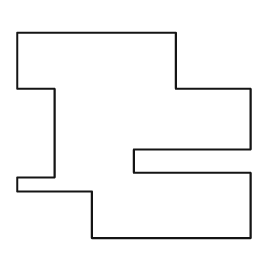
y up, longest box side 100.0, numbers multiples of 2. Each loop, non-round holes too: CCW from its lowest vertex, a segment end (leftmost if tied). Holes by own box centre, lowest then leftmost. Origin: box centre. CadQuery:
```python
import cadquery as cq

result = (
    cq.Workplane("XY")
    .moveTo(-18.0, -44.0)
    .lineTo(50.0, -44.0)
    .lineTo(50.0, -16.0)
    .lineTo(0.0, -16.0)
    .lineTo(0.0, -6.0)
    .lineTo(50.0, -6.0)
    .lineTo(50.0, 20.0)
    .lineTo(18.0, 20.0)
    .lineTo(18.0, 44.0)
    .lineTo(-50.0, 44.0)
    .lineTo(-50.0, 20.0)
    .lineTo(-34.0, 20.0)
    .lineTo(-34.0, -18.0)
    .lineTo(-50.0, -18.0)
    .lineTo(-50.0, -24.0)
    .lineTo(-18.0, -24.0)
    .close()
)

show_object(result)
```